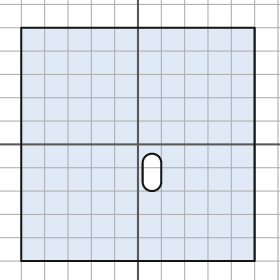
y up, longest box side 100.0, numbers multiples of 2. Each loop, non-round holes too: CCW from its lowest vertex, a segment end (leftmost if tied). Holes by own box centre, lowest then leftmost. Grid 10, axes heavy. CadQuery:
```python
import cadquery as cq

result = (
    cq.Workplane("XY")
    .moveTo(-50.0, -50.0)
    .lineTo(50.0, -50.0)
    .lineTo(50.0, 50.0)
    .lineTo(-50.0, 50.0)
    .close()
    .moveTo(2.0, -16.0)
    .threePointArc((6.0, -20.0), (10.0, -16.0))
    .lineTo(10.0, -8.0)
    .threePointArc((6.0, -4.0), (2.0, -8.0))
    .close()
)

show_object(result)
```